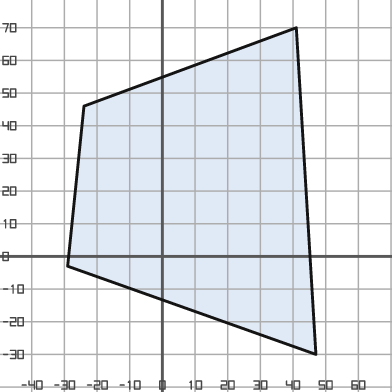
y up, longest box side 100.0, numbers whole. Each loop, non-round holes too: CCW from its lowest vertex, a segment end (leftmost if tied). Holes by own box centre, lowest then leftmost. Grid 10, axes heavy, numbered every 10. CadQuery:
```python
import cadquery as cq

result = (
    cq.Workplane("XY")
    .moveTo(47.0, -30.0)
    .lineTo(41.0, 70.0)
    .lineTo(-24.0, 46.0)
    .lineTo(-29.0, -3.0)
    .close()
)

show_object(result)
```